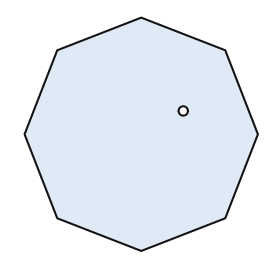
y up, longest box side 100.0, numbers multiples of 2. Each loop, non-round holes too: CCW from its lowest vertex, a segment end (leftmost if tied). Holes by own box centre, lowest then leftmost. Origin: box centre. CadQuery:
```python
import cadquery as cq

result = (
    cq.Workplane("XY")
    .moveTo(0.0, -50.0)
    .lineTo(36.0, -36.0)
    .lineTo(50.0, 0.0)
    .lineTo(36.0, 36.0)
    .lineTo(0.0, 50.0)
    .lineTo(-36.0, 36.0)
    .lineTo(-50.0, 0.0)
    .lineTo(-36.0, -36.0)
    .close()
    .moveTo(18.0, 10.0)
    .circle(2.0)
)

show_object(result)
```